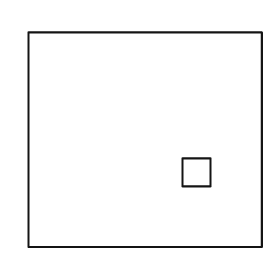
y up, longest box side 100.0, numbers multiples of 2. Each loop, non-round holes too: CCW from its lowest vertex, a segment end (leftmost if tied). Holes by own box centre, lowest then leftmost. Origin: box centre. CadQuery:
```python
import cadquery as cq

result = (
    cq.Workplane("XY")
    .moveTo(-50.0, -46.0)
    .lineTo(50.0, -46.0)
    .lineTo(50.0, 46.0)
    .lineTo(-50.0, 46.0)
    .close()
    .moveTo(16.0, -20.0)
    .lineTo(28.0, -20.0)
    .lineTo(28.0, -8.0)
    .lineTo(16.0, -8.0)
    .close()
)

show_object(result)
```